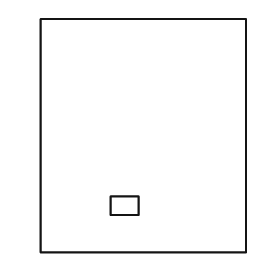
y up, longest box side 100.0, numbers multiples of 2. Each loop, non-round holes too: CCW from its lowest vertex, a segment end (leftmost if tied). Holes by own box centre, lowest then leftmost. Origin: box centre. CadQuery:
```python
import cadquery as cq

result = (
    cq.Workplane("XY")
    .moveTo(-44.0, -50.0)
    .lineTo(44.0, -50.0)
    .lineTo(44.0, 50.0)
    .lineTo(-44.0, 50.0)
    .close()
    .moveTo(-14.0, -34.0)
    .lineTo(-2.0, -34.0)
    .lineTo(-2.0, -26.0)
    .lineTo(-14.0, -26.0)
    .close()
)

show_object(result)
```